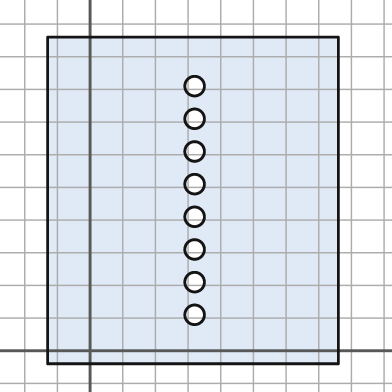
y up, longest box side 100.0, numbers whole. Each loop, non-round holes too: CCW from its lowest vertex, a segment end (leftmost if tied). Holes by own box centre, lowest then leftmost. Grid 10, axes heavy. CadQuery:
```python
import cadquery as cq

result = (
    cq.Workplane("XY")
    .moveTo(-13.0, -4.0)
    .lineTo(76.0, -4.0)
    .lineTo(76.0, 96.0)
    .lineTo(-13.0, 96.0)
    .close()
    .moveTo(32.0, 11.0)
    .circle(3.0)
    .moveTo(32.0, 21.0)
    .circle(3.0)
    .moveTo(32.0, 31.0)
    .circle(3.0)
    .moveTo(32.0, 41.0)
    .circle(3.0)
    .moveTo(32.0, 51.0)
    .circle(3.0)
    .moveTo(32.0, 61.0)
    .circle(3.0)
    .moveTo(32.0, 71.0)
    .circle(3.0)
    .moveTo(32.0, 81.0)
    .circle(3.0)
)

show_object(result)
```